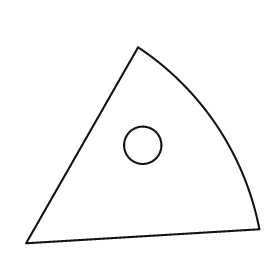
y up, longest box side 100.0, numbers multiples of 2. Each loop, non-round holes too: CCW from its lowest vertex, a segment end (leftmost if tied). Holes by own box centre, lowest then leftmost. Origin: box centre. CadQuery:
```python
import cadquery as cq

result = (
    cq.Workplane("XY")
    .moveTo(-50.0, -42.0)
    .lineTo(50.0, -36.0)
    .threePointArc((32.0, 8.0), (-2.0, 42.0))
    .close()
    .moveTo(0.0, 0.0)
    .circle(8.0)
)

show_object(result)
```